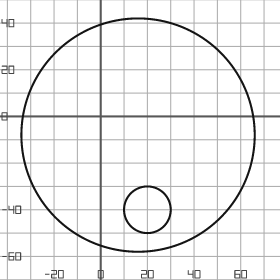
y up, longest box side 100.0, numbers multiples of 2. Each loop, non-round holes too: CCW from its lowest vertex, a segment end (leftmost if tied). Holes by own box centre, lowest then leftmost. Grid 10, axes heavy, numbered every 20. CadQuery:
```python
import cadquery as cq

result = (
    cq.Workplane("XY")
    .moveTo(16.0, -8.0)
    .circle(50.0)
    .moveTo(20.0, -40.0)
    .circle(10.0)
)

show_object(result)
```